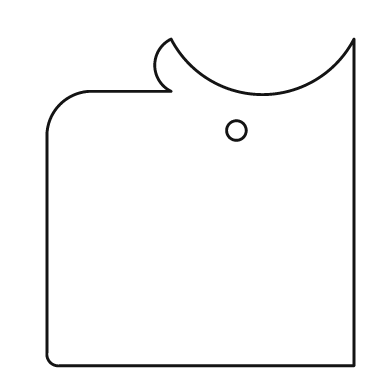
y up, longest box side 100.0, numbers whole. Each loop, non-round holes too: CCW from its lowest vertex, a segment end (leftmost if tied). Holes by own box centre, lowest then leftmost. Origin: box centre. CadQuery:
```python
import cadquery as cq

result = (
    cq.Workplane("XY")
    .moveTo(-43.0, -50.0)
    .lineTo(47.0, -50.0)
    .lineTo(47.0, 50.0)
    .threePointArc((19.0, 33.0), (-9.0, 50.0))
    .threePointArc((-14.0, 42.0), (-9.0, 34.0))
    .lineTo(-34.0, 34.0)
    .threePointArc((-43.0, 30.0), (-47.0, 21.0))
    .lineTo(-47.0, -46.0)
    .threePointArc((-46.0, -49.0), (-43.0, -50.0))
    .close()
    .moveTo(11.0, 22.0)
    .circle(3.0)
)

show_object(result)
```